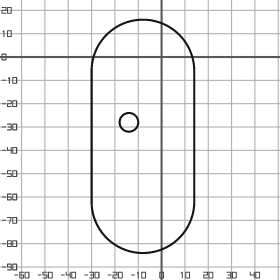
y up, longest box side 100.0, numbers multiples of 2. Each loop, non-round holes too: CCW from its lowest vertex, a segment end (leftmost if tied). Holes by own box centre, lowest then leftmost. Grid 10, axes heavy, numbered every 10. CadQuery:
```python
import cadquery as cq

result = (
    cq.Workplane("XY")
    .moveTo(-30.0, -62.0)
    .threePointArc((-8.0, -84.0), (14.0, -62.0))
    .lineTo(14.0, -6.0)
    .threePointArc((-8.0, 16.0), (-30.0, -6.0))
    .close()
    .moveTo(-14.0, -28.0)
    .circle(4.0)
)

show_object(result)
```